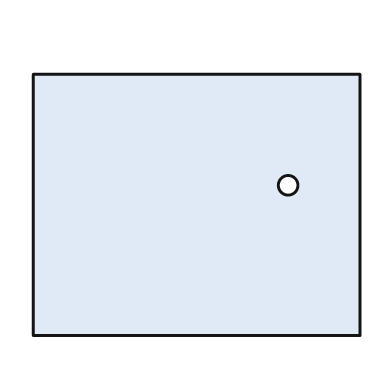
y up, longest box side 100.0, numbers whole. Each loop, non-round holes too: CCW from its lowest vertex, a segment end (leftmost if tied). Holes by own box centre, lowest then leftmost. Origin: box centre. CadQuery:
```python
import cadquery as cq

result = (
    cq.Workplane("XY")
    .moveTo(-50.0, -40.0)
    .lineTo(50.0, -40.0)
    .lineTo(50.0, 40.0)
    .lineTo(-50.0, 40.0)
    .close()
    .moveTo(28.0, 6.0)
    .circle(3.0)
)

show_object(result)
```